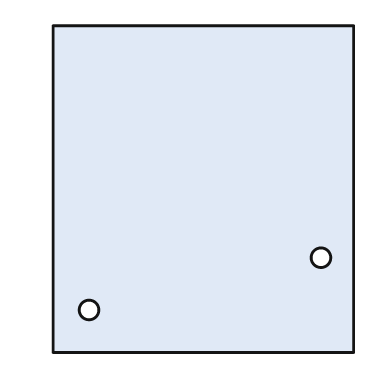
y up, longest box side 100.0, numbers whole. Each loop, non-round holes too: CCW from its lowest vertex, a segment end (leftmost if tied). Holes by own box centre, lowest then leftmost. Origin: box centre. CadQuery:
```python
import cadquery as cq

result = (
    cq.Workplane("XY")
    .moveTo(-46.0, -50.0)
    .lineTo(46.0, -50.0)
    .lineTo(46.0, 50.0)
    .lineTo(-46.0, 50.0)
    .close()
    .moveTo(-35.0, -37.0)
    .circle(3.0)
    .moveTo(36.0, -21.0)
    .circle(3.0)
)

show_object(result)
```